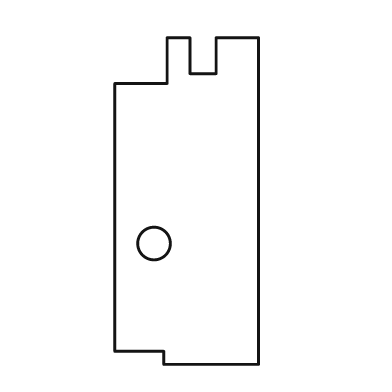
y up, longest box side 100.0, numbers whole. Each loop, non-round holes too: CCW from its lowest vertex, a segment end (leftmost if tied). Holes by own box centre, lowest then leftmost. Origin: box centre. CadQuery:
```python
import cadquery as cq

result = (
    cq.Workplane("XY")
    .moveTo(-7.0, -50.0)
    .lineTo(22.0, -50.0)
    .lineTo(22.0, 50.0)
    .lineTo(9.0, 50.0)
    .lineTo(9.0, 39.0)
    .lineTo(1.0, 39.0)
    .lineTo(1.0, 50.0)
    .lineTo(-6.0, 50.0)
    .lineTo(-6.0, 36.0)
    .lineTo(-22.0, 36.0)
    .lineTo(-22.0, -46.0)
    .lineTo(-7.0, -46.0)
    .close()
    .moveTo(-10.0, -13.0)
    .circle(5.0)
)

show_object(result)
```